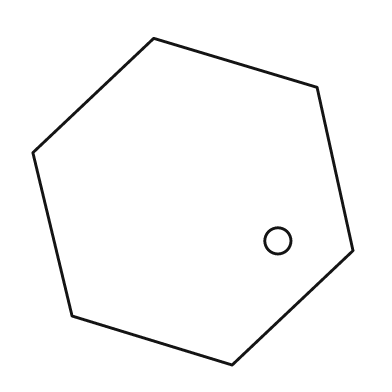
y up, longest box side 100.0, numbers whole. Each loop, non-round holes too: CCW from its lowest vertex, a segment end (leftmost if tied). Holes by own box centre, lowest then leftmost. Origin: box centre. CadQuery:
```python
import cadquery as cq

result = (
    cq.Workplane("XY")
    .moveTo(12.0, -50.0)
    .lineTo(49.0, -15.0)
    .lineTo(38.0, 35.0)
    .lineTo(-12.0, 50.0)
    .lineTo(-49.0, 15.0)
    .lineTo(-37.0, -35.0)
    .close()
    .moveTo(26.0, -12.0)
    .circle(4.0)
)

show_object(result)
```